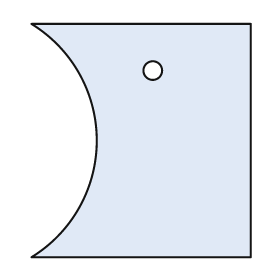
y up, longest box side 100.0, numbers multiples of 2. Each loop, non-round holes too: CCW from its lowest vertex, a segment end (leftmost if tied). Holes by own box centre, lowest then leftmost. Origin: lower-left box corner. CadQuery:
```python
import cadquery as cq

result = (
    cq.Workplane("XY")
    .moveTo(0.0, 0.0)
    .lineTo(94.0, 0.0)
    .lineTo(94.0, 100.0)
    .lineTo(0.0, 100.0)
    .threePointArc((28.0, 50.0), (0.0, 0.0))
    .close()
    .moveTo(52.0, 80.0)
    .circle(4.0)
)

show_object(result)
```